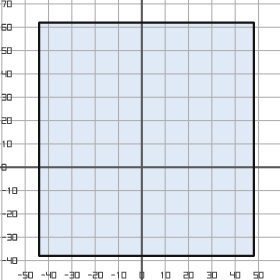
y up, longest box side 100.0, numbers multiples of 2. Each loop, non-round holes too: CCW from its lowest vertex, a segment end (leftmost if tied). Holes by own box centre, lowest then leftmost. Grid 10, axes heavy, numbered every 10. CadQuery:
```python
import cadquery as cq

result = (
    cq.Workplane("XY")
    .moveTo(-44.0, -38.0)
    .lineTo(48.0, -38.0)
    .lineTo(48.0, 62.0)
    .lineTo(-44.0, 62.0)
    .close()
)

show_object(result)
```